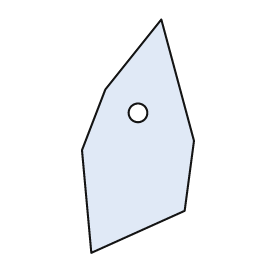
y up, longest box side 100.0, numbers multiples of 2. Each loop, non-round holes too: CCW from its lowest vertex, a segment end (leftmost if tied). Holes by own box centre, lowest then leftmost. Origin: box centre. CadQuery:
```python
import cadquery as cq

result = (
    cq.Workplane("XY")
    .moveTo(-20.0, -50.0)
    .lineTo(20.0, -32.0)
    .lineTo(24.0, -2.0)
    .lineTo(10.0, 50.0)
    .lineTo(-14.0, 20.0)
    .lineTo(-24.0, -6.0)
    .close()
    .moveTo(0.0, 10.0)
    .circle(4.0)
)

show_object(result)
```